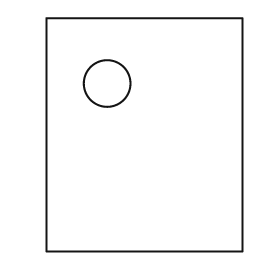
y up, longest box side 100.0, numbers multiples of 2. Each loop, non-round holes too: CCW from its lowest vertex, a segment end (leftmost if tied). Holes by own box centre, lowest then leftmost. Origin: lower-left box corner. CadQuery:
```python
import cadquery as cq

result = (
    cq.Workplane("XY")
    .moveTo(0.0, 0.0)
    .lineTo(84.0, 0.0)
    .lineTo(84.0, 100.0)
    .lineTo(0.0, 100.0)
    .close()
    .moveTo(26.0, 72.0)
    .circle(10.0)
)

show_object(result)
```